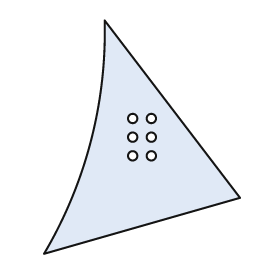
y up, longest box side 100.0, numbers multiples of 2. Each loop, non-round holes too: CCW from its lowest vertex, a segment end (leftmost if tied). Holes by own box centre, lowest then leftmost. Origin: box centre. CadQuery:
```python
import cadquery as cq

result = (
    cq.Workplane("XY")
    .moveTo(-42.0, -50.0)
    .lineTo(42.0, -26.0)
    .lineTo(-16.0, 50.0)
    .threePointArc((-22.0, -2.0), (-42.0, -50.0))
    .close()
    .moveTo(-4.0, -8.0)
    .circle(2.0)
    .moveTo(4.0, -8.0)
    .circle(2.0)
    .moveTo(-4.0, 0.0)
    .circle(2.0)
    .moveTo(4.0, 0.0)
    .circle(2.0)
    .moveTo(-4.0, 8.0)
    .circle(2.0)
    .moveTo(4.0, 8.0)
    .circle(2.0)
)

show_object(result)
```